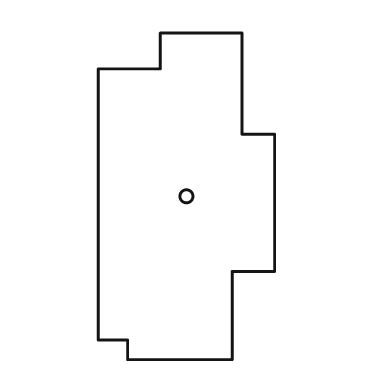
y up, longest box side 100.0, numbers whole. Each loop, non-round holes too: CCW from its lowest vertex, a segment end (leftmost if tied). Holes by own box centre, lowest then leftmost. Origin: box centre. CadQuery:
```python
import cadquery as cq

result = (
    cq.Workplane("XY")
    .moveTo(-18.0, -50.0)
    .lineTo(14.0, -50.0)
    .lineTo(14.0, -23.0)
    .lineTo(27.0, -23.0)
    .lineTo(27.0, 19.0)
    .lineTo(17.0, 19.0)
    .lineTo(17.0, 50.0)
    .lineTo(-8.0, 50.0)
    .lineTo(-8.0, 39.0)
    .lineTo(-27.0, 39.0)
    .lineTo(-27.0, -44.0)
    .lineTo(-18.0, -44.0)
    .close()
    .moveTo(0.0, 0.0)
    .circle(2.0)
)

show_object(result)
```